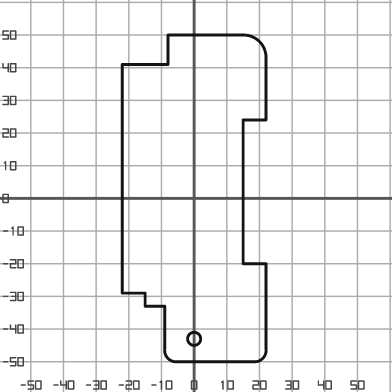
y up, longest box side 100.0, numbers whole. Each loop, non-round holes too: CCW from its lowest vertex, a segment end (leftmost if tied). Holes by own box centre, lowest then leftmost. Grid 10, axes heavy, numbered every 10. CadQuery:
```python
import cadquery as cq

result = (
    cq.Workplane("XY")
    .moveTo(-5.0, -50.0)
    .lineTo(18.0, -50.0)
    .threePointArc((21.0, -49.0), (22.0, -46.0))
    .lineTo(22.0, -20.0)
    .lineTo(15.0, -20.0)
    .lineTo(15.0, 24.0)
    .lineTo(22.0, 24.0)
    .lineTo(22.0, 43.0)
    .threePointArc((20.0, 48.0), (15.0, 50.0))
    .lineTo(-8.0, 50.0)
    .lineTo(-8.0, 41.0)
    .lineTo(-22.0, 41.0)
    .lineTo(-22.0, -29.0)
    .lineTo(-15.0, -29.0)
    .lineTo(-15.0, -33.0)
    .lineTo(-9.0, -33.0)
    .lineTo(-9.0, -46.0)
    .threePointArc((-8.0, -49.0), (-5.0, -50.0))
    .close()
    .moveTo(0.0, -43.0)
    .circle(2.0)
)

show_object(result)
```